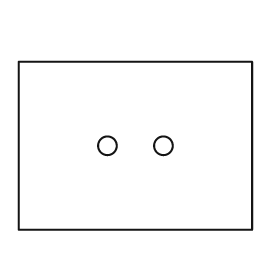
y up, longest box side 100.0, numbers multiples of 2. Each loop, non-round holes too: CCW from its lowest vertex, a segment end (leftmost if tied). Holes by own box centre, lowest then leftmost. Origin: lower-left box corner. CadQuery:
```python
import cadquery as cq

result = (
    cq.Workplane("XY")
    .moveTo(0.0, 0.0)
    .lineTo(100.0, 0.0)
    .lineTo(100.0, 72.0)
    .lineTo(0.0, 72.0)
    .close()
    .moveTo(38.0, 36.0)
    .circle(4.0)
    .moveTo(62.0, 36.0)
    .circle(4.0)
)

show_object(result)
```